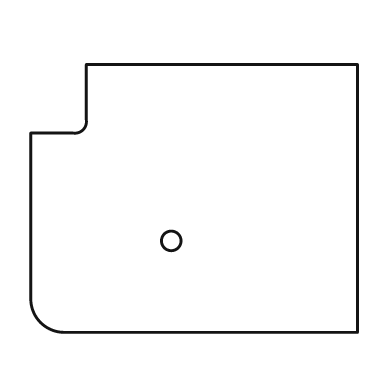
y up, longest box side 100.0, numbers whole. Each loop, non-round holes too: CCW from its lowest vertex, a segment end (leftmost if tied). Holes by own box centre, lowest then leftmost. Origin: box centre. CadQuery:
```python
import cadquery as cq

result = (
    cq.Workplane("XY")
    .moveTo(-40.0, -41.0)
    .lineTo(50.0, -41.0)
    .lineTo(50.0, 41.0)
    .lineTo(-33.0, 41.0)
    .lineTo(-33.0, 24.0)
    .threePointArc((-34.0, 21.0), (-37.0, 20.0))
    .lineTo(-50.0, 20.0)
    .lineTo(-50.0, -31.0)
    .threePointArc((-47.0, -38.0), (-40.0, -41.0))
    .close()
    .moveTo(-7.0, -13.0)
    .circle(3.0)
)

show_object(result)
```